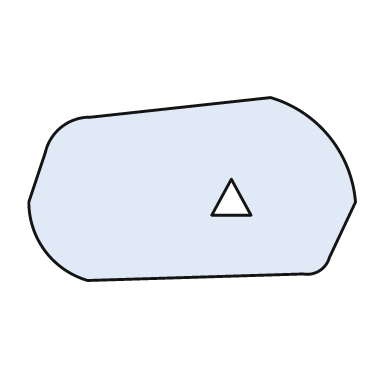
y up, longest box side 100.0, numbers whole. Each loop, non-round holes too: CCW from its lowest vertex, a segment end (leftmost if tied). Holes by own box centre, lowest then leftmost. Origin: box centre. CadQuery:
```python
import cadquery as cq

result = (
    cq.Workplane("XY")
    .moveTo(-32.0, -28.0)
    .lineTo(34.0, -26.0)
    .threePointArc((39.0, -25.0), (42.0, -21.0))
    .lineTo(50.0, -4.0)
    .threePointArc((42.0, 16.0), (24.0, 28.0))
    .lineTo(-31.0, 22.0)
    .threePointArc((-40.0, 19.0), (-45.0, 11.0))
    .lineTo(-50.0, -4.0)
    .threePointArc((-45.0, -19.0), (-32.0, -28.0))
    .close()
    .moveTo(6.0, -8.0)
    .lineTo(18.0, -8.0)
    .lineTo(12.0, 3.0)
    .close()
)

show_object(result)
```